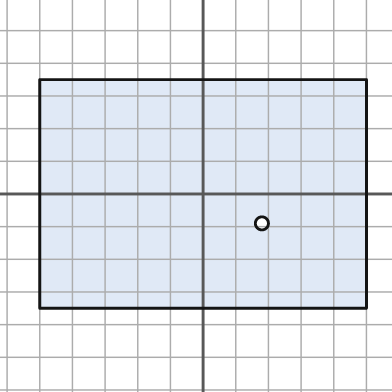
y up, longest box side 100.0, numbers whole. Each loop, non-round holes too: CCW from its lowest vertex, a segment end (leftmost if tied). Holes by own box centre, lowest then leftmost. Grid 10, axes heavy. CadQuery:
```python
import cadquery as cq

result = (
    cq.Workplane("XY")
    .moveTo(-50.0, -35.0)
    .lineTo(50.0, -35.0)
    .lineTo(50.0, 35.0)
    .lineTo(-50.0, 35.0)
    .close()
    .moveTo(18.0, -9.0)
    .circle(2.0)
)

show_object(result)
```